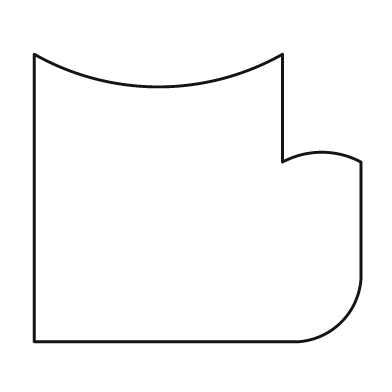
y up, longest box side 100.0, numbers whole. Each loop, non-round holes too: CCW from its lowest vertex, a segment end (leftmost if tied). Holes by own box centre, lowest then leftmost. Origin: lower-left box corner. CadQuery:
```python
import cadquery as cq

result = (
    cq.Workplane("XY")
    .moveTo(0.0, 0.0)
    .lineTo(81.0, 0.0)
    .threePointArc((94.0, 6.0), (100.0, 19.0))
    .lineTo(100.0, 55.0)
    .threePointArc((88.0, 58.0), (76.0, 55.0))
    .lineTo(76.0, 88.0)
    .threePointArc((38.0, 78.0), (0.0, 88.0))
    .close()
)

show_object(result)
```